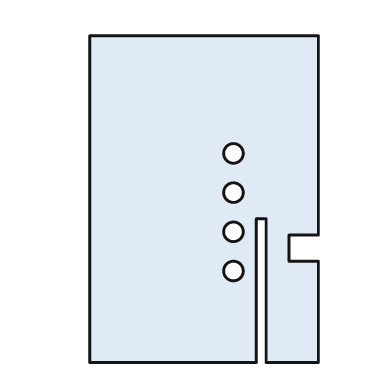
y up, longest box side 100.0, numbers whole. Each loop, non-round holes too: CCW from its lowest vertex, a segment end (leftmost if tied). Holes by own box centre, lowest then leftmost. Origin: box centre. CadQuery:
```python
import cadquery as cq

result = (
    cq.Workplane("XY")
    .moveTo(-35.0, -50.0)
    .lineTo(16.0, -50.0)
    .lineTo(16.0, -6.0)
    .lineTo(19.0, -6.0)
    .lineTo(19.0, -50.0)
    .lineTo(35.0, -50.0)
    .lineTo(35.0, -19.0)
    .lineTo(26.0, -19.0)
    .lineTo(26.0, -11.0)
    .lineTo(35.0, -11.0)
    .lineTo(35.0, 50.0)
    .lineTo(-35.0, 50.0)
    .close()
    .moveTo(9.0, -22.0)
    .circle(3.0)
    .moveTo(9.0, -10.0)
    .circle(3.0)
    .moveTo(9.0, 2.0)
    .circle(3.0)
    .moveTo(9.0, 14.0)
    .circle(3.0)
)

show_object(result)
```